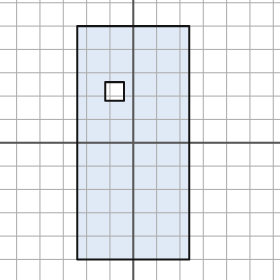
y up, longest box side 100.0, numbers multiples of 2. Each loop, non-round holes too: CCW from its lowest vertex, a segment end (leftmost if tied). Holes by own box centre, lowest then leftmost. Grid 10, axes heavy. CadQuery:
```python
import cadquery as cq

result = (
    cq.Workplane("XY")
    .moveTo(-24.0, -50.0)
    .lineTo(24.0, -50.0)
    .lineTo(24.0, 50.0)
    .lineTo(-24.0, 50.0)
    .close()
    .moveTo(-12.0, 18.0)
    .lineTo(-4.0, 18.0)
    .lineTo(-4.0, 26.0)
    .lineTo(-12.0, 26.0)
    .close()
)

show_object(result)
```